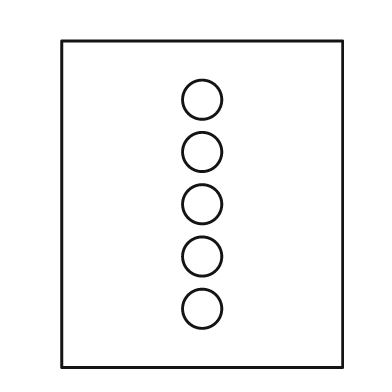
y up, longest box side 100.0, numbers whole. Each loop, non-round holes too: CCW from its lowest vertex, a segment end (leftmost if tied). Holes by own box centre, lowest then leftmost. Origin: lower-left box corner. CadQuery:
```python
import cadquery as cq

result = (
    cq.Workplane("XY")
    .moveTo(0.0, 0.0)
    .lineTo(86.0, 0.0)
    .lineTo(86.0, 100.0)
    .lineTo(0.0, 100.0)
    .close()
    .moveTo(43.0, 18.0)
    .circle(6.0)
    .moveTo(43.0, 34.0)
    .circle(6.0)
    .moveTo(43.0, 50.0)
    .circle(6.0)
    .moveTo(43.0, 66.0)
    .circle(6.0)
    .moveTo(43.0, 82.0)
    .circle(6.0)
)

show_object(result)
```